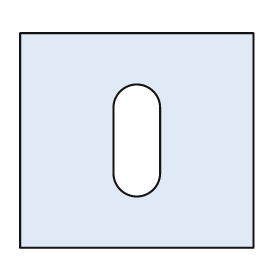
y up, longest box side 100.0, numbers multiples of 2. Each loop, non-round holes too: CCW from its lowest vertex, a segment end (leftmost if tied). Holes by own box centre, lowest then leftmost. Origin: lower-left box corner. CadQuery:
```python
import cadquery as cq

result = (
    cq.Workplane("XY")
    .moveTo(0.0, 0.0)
    .lineTo(100.0, 0.0)
    .lineTo(100.0, 92.0)
    .lineTo(0.0, 92.0)
    .close()
    .moveTo(40.0, 32.0)
    .threePointArc((50.0, 22.0), (60.0, 32.0))
    .lineTo(60.0, 60.0)
    .threePointArc((50.0, 70.0), (40.0, 60.0))
    .close()
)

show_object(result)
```